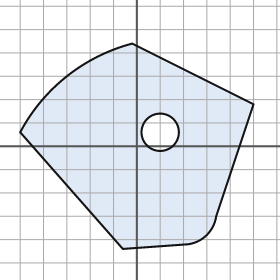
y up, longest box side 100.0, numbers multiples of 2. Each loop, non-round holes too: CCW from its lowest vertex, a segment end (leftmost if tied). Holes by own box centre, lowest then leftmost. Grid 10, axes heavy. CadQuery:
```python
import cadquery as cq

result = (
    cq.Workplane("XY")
    .moveTo(-6.0, -44.0)
    .lineTo(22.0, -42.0)
    .threePointArc((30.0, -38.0), (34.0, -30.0))
    .lineTo(50.0, 18.0)
    .lineTo(-2.0, 44.0)
    .threePointArc((-30.0, 30.0), (-50.0, 6.0))
    .close()
    .moveTo(10.0, 6.0)
    .circle(8.0)
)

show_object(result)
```